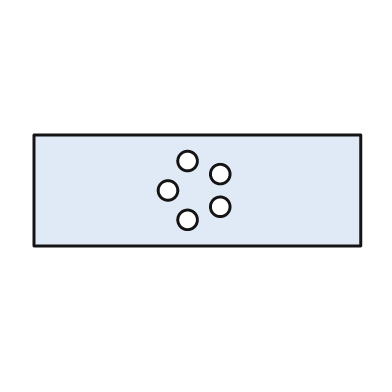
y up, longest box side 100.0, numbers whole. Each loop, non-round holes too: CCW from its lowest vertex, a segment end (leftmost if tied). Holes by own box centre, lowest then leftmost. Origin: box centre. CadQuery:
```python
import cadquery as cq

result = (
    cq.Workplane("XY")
    .moveTo(-50.0, -17.0)
    .lineTo(50.0, -17.0)
    .lineTo(50.0, 17.0)
    .lineTo(-50.0, 17.0)
    .close()
    .moveTo(-3.0, -9.0)
    .circle(3.0)
    .moveTo(7.0, -5.0)
    .circle(3.0)
    .moveTo(-9.0, 0.0)
    .circle(3.0)
    .moveTo(7.0, 5.0)
    .circle(3.0)
    .moveTo(-3.0, 9.0)
    .circle(3.0)
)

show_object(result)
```